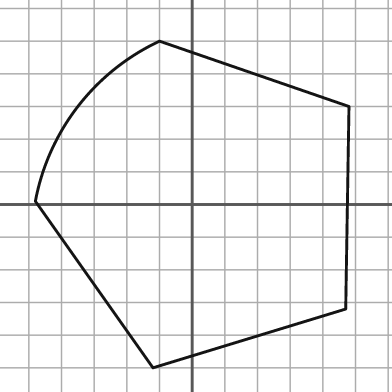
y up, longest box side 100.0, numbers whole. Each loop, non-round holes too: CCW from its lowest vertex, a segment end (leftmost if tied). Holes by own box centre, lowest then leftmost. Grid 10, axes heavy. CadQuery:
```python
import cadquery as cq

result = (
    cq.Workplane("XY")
    .moveTo(-12.0, -50.0)
    .lineTo(47.0, -32.0)
    .lineTo(48.0, 30.0)
    .lineTo(-10.0, 50.0)
    .threePointArc((-35.0, 30.0), (-48.0, 1.0))
    .close()
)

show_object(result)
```